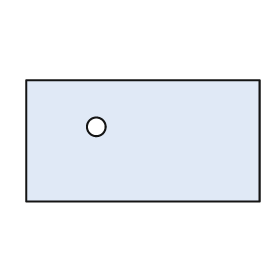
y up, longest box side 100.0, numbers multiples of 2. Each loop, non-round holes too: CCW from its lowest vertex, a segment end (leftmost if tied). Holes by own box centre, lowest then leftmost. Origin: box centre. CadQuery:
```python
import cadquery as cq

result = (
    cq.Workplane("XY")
    .moveTo(-50.0, -26.0)
    .lineTo(50.0, -26.0)
    .lineTo(50.0, 26.0)
    .lineTo(-50.0, 26.0)
    .close()
    .moveTo(-20.0, 6.0)
    .circle(4.0)
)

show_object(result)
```